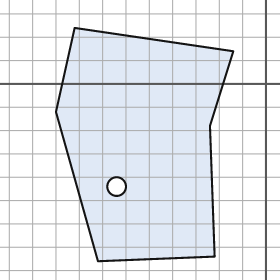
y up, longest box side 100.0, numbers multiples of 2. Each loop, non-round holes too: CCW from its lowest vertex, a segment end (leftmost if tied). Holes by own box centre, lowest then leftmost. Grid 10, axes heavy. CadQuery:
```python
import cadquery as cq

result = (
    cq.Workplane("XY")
    .moveTo(-72.0, -76.0)
    .lineTo(-22.0, -74.0)
    .lineTo(-24.0, -18.0)
    .lineTo(-14.0, 14.0)
    .lineTo(-82.0, 24.0)
    .lineTo(-90.0, -12.0)
    .close()
    .moveTo(-64.0, -44.0)
    .circle(4.0)
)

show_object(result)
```